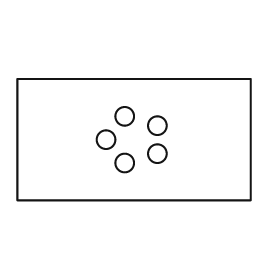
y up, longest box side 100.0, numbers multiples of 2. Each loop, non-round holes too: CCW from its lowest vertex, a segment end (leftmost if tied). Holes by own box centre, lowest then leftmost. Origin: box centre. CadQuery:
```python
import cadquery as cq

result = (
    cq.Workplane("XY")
    .moveTo(-50.0, -26.0)
    .lineTo(50.0, -26.0)
    .lineTo(50.0, 26.0)
    .lineTo(-50.0, 26.0)
    .close()
    .moveTo(-4.0, -10.0)
    .circle(4.0)
    .moveTo(10.0, -6.0)
    .circle(4.0)
    .moveTo(-12.0, 0.0)
    .circle(4.0)
    .moveTo(10.0, 6.0)
    .circle(4.0)
    .moveTo(-4.0, 10.0)
    .circle(4.0)
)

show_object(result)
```